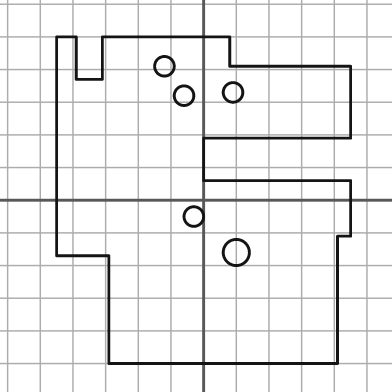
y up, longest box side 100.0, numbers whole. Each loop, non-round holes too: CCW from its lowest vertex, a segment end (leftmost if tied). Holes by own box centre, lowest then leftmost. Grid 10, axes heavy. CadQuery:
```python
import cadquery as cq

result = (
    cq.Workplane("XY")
    .moveTo(-29.0, -50.0)
    .lineTo(41.0, -50.0)
    .lineTo(41.0, -11.0)
    .lineTo(45.0, -11.0)
    .lineTo(45.0, 6.0)
    .lineTo(0.0, 6.0)
    .lineTo(0.0, 19.0)
    .lineTo(45.0, 19.0)
    .lineTo(45.0, 41.0)
    .lineTo(8.0, 41.0)
    .lineTo(8.0, 50.0)
    .lineTo(-31.0, 50.0)
    .lineTo(-31.0, 37.0)
    .lineTo(-39.0, 37.0)
    .lineTo(-39.0, 50.0)
    .lineTo(-45.0, 50.0)
    .lineTo(-45.0, -17.0)
    .lineTo(-29.0, -17.0)
    .close()
    .moveTo(10.0, -16.0)
    .circle(4.0)
    .moveTo(-3.0, -5.0)
    .circle(3.0)
    .moveTo(-6.0, 32.0)
    .circle(3.0)
    .moveTo(9.0, 33.0)
    .circle(3.0)
    .moveTo(-12.0, 41.0)
    .circle(3.0)
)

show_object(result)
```